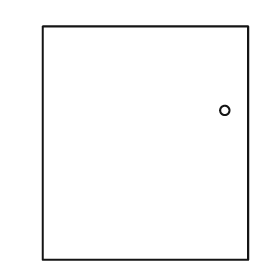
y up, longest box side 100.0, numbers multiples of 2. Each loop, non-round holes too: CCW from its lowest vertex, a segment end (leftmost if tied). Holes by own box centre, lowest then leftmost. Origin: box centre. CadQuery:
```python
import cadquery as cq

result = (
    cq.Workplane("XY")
    .moveTo(-44.0, -50.0)
    .lineTo(44.0, -50.0)
    .lineTo(44.0, 50.0)
    .lineTo(-44.0, 50.0)
    .close()
    .moveTo(34.0, 14.0)
    .circle(2.0)
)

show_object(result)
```